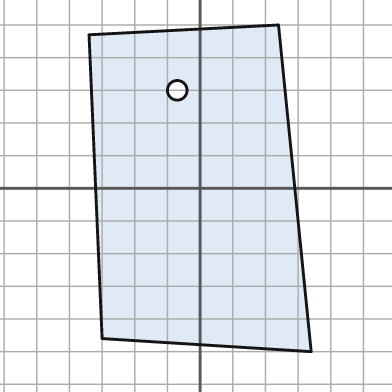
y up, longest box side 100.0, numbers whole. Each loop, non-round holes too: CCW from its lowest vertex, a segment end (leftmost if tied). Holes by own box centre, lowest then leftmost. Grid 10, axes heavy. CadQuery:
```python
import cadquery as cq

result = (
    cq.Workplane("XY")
    .moveTo(34.0, -50.0)
    .lineTo(24.0, 50.0)
    .lineTo(-34.0, 47.0)
    .lineTo(-30.0, -46.0)
    .close()
    .moveTo(-7.0, 30.0)
    .circle(3.0)
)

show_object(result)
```